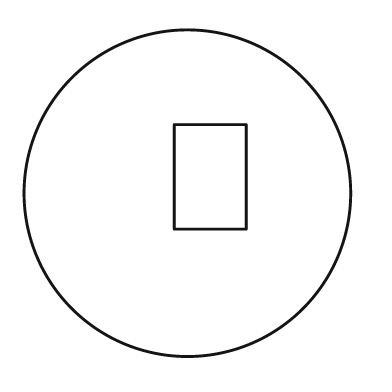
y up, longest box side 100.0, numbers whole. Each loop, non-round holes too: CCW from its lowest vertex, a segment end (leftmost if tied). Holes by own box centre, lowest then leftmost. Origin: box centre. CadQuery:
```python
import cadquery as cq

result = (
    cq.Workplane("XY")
    .moveTo(0.0, 0.0)
    .circle(50.0)
    .moveTo(-4.0, -11.0)
    .lineTo(18.0, -11.0)
    .lineTo(18.0, 21.0)
    .lineTo(-4.0, 21.0)
    .close()
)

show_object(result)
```